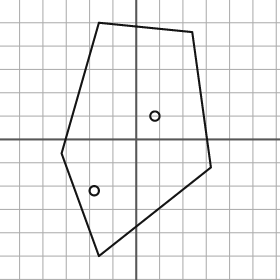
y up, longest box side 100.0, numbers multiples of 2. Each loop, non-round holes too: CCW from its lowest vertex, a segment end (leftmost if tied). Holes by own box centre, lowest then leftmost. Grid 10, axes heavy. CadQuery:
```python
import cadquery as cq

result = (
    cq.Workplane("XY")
    .moveTo(-16.0, -50.0)
    .lineTo(32.0, -12.0)
    .lineTo(24.0, 46.0)
    .lineTo(-16.0, 50.0)
    .lineTo(-32.0, -6.0)
    .close()
    .moveTo(-18.0, -22.0)
    .circle(2.0)
    .moveTo(8.0, 10.0)
    .circle(2.0)
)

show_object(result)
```